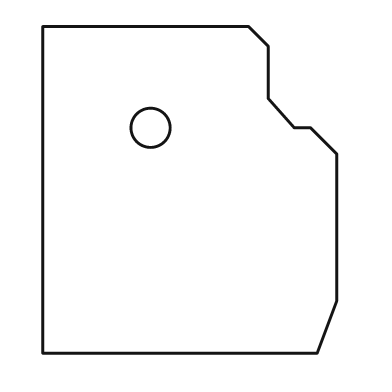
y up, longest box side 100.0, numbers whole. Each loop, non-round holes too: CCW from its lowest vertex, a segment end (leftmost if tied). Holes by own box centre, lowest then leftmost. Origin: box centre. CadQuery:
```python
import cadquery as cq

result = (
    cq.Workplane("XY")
    .moveTo(-45.0, -50.0)
    .lineTo(39.0, -50.0)
    .lineTo(45.0, -34.0)
    .lineTo(45.0, 11.0)
    .lineTo(37.0, 19.0)
    .lineTo(32.0, 19.0)
    .lineTo(24.0, 28.0)
    .lineTo(24.0, 44.0)
    .lineTo(18.0, 50.0)
    .lineTo(-45.0, 50.0)
    .close()
    .moveTo(-12.0, 19.0)
    .circle(6.0)
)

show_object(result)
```